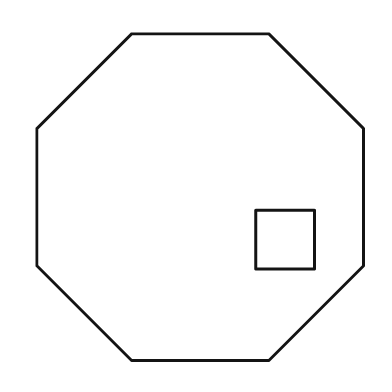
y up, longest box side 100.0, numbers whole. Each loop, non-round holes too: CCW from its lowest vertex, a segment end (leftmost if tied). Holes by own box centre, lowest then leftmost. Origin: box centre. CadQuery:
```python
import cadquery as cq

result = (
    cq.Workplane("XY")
    .moveTo(-21.0, -50.0)
    .lineTo(21.0, -50.0)
    .lineTo(50.0, -21.0)
    .lineTo(50.0, 21.0)
    .lineTo(21.0, 50.0)
    .lineTo(-21.0, 50.0)
    .lineTo(-50.0, 21.0)
    .lineTo(-50.0, -21.0)
    .close()
    .moveTo(17.0, -22.0)
    .lineTo(35.0, -22.0)
    .lineTo(35.0, -4.0)
    .lineTo(17.0, -4.0)
    .close()
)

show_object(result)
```